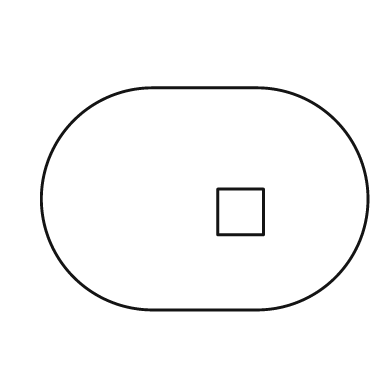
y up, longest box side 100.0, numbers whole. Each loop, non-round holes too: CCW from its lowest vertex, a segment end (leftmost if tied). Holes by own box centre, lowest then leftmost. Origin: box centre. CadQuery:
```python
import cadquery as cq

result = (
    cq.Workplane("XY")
    .moveTo(-16.0, -34.0)
    .lineTo(16.0, -34.0)
    .threePointArc((50.0, 0.0), (16.0, 34.0))
    .lineTo(-16.0, 34.0)
    .threePointArc((-50.0, 0.0), (-16.0, -34.0))
    .close()
    .moveTo(4.0, -11.0)
    .lineTo(18.0, -11.0)
    .lineTo(18.0, 3.0)
    .lineTo(4.0, 3.0)
    .close()
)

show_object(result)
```